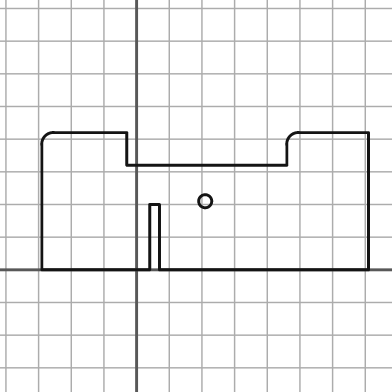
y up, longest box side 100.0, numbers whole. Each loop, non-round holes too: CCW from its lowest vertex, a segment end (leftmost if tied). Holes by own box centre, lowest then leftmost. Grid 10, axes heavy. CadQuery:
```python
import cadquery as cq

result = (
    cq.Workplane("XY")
    .moveTo(-29.0, 0.0)
    .lineTo(4.0, 0.0)
    .lineTo(4.0, 20.0)
    .lineTo(7.0, 20.0)
    .lineTo(7.0, 0.0)
    .lineTo(71.0, 0.0)
    .lineTo(71.0, 42.0)
    .lineTo(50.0, 42.0)
    .threePointArc((47.0, 41.0), (46.0, 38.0))
    .lineTo(46.0, 32.0)
    .lineTo(-3.0, 32.0)
    .lineTo(-3.0, 42.0)
    .lineTo(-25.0, 42.0)
    .threePointArc((-28.0, 41.0), (-29.0, 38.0))
    .close()
    .moveTo(21.0, 21.0)
    .circle(2.0)
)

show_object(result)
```